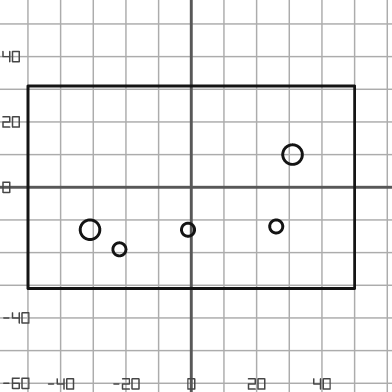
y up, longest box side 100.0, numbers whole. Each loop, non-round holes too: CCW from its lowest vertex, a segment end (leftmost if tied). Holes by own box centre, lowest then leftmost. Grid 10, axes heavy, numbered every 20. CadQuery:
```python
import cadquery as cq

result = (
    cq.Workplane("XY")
    .moveTo(-50.0, -31.0)
    .lineTo(50.0, -31.0)
    .lineTo(50.0, 31.0)
    .lineTo(-50.0, 31.0)
    .close()
    .moveTo(-22.0, -19.0)
    .circle(2.0)
    .moveTo(-31.0, -13.0)
    .circle(3.0)
    .moveTo(-1.0, -13.0)
    .circle(2.0)
    .moveTo(26.0, -12.0)
    .circle(2.0)
    .moveTo(31.0, 10.0)
    .circle(3.0)
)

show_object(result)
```